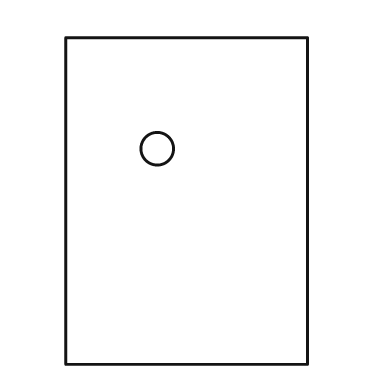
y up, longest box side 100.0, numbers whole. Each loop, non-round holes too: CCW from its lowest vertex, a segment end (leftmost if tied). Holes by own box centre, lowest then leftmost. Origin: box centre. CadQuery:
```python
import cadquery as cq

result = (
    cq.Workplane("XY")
    .moveTo(-37.0, -50.0)
    .lineTo(37.0, -50.0)
    .lineTo(37.0, 50.0)
    .lineTo(-37.0, 50.0)
    .close()
    .moveTo(-9.0, 16.0)
    .circle(5.0)
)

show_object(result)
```